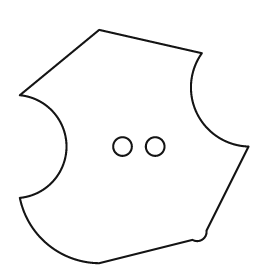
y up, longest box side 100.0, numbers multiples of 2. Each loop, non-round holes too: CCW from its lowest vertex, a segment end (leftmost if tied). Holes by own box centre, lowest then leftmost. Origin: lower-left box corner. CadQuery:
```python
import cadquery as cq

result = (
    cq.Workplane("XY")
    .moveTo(34.0, 0.0)
    .lineTo(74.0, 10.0)
    .threePointArc((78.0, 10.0), (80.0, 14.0))
    .lineTo(98.0, 50.0)
    .threePointArc((76.0, 64.0), (78.0, 90.0))
    .lineTo(34.0, 100.0)
    .lineTo(0.0, 72.0)
    .threePointArc((20.0, 50.0), (0.0, 28.0))
    .threePointArc((12.0, 8.0), (34.0, 0.0))
    .close()
    .moveTo(44.0, 50.0)
    .circle(4.0)
    .moveTo(58.0, 50.0)
    .circle(4.0)
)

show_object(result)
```